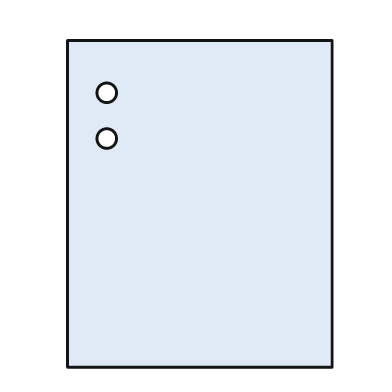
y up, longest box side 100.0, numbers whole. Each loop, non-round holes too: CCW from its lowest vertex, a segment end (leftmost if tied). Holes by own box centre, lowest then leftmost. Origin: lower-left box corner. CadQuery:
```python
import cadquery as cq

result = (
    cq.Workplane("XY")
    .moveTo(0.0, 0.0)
    .lineTo(81.0, 0.0)
    .lineTo(81.0, 100.0)
    .lineTo(0.0, 100.0)
    .close()
    .moveTo(12.0, 70.0)
    .circle(3.0)
    .moveTo(12.0, 84.0)
    .circle(3.0)
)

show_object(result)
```